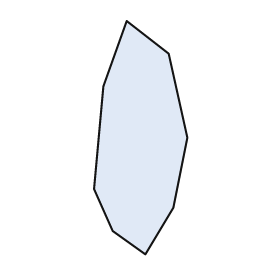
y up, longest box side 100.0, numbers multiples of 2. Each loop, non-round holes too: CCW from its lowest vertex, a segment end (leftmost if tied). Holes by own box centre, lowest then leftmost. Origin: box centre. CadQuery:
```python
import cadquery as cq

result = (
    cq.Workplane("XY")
    .moveTo(2.0, -50.0)
    .lineTo(14.0, -30.0)
    .lineTo(20.0, 0.0)
    .lineTo(12.0, 36.0)
    .lineTo(-6.0, 50.0)
    .lineTo(-16.0, 22.0)
    .lineTo(-20.0, -22.0)
    .lineTo(-12.0, -40.0)
    .close()
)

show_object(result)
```